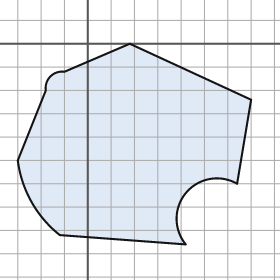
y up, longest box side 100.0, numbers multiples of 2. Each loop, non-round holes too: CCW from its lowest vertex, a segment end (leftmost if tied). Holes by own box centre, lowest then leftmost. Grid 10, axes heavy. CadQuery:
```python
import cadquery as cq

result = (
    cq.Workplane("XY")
    .moveTo(42.0, -86.0)
    .threePointArc((42.0, -64.0), (64.0, -60.0))
    .lineTo(70.0, -24.0)
    .lineTo(18.0, 0.0)
    .lineTo(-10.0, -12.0)
    .threePointArc((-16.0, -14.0), (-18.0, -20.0))
    .lineTo(-30.0, -50.0)
    .threePointArc((-24.0, -68.0), (-12.0, -82.0))
    .close()
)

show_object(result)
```